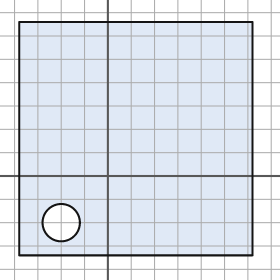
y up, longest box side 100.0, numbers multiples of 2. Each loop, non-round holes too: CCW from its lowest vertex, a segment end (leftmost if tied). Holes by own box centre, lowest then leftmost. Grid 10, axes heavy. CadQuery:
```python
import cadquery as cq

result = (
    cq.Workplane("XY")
    .moveTo(-38.0, -34.0)
    .lineTo(62.0, -34.0)
    .lineTo(62.0, 66.0)
    .lineTo(-38.0, 66.0)
    .close()
    .moveTo(-20.0, -20.0)
    .circle(8.0)
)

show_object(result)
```